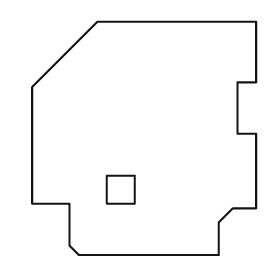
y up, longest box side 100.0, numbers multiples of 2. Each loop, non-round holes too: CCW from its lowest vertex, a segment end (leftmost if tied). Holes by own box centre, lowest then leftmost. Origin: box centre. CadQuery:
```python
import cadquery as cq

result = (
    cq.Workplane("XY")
    .moveTo(-28.0, -50.0)
    .lineTo(32.0, -50.0)
    .lineTo(32.0, -36.0)
    .lineTo(38.0, -30.0)
    .lineTo(48.0, -30.0)
    .lineTo(48.0, 2.0)
    .lineTo(40.0, 2.0)
    .lineTo(40.0, 24.0)
    .lineTo(48.0, 24.0)
    .lineTo(48.0, 50.0)
    .lineTo(-20.0, 50.0)
    .lineTo(-48.0, 22.0)
    .lineTo(-48.0, -28.0)
    .lineTo(-32.0, -28.0)
    .lineTo(-32.0, -46.0)
    .close()
    .moveTo(-16.0, -28.0)
    .lineTo(-4.0, -28.0)
    .lineTo(-4.0, -16.0)
    .lineTo(-16.0, -16.0)
    .close()
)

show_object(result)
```